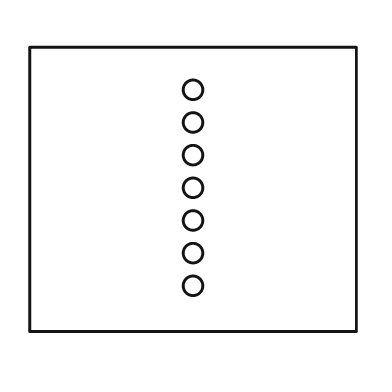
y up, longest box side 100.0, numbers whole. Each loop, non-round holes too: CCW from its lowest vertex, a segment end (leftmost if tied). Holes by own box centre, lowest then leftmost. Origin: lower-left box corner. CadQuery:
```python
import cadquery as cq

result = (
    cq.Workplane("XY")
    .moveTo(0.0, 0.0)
    .lineTo(100.0, 0.0)
    .lineTo(100.0, 87.0)
    .lineTo(0.0, 87.0)
    .close()
    .moveTo(50.0, 14.0)
    .circle(3.0)
    .moveTo(50.0, 24.0)
    .circle(3.0)
    .moveTo(50.0, 34.0)
    .circle(3.0)
    .moveTo(50.0, 44.0)
    .circle(3.0)
    .moveTo(50.0, 54.0)
    .circle(3.0)
    .moveTo(50.0, 64.0)
    .circle(3.0)
    .moveTo(50.0, 74.0)
    .circle(3.0)
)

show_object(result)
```